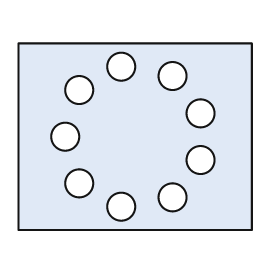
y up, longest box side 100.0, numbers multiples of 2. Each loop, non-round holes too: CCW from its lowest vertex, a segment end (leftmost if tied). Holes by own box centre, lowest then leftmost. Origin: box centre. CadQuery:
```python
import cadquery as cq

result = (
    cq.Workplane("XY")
    .moveTo(-50.0, -40.0)
    .lineTo(50.0, -40.0)
    .lineTo(50.0, 40.0)
    .lineTo(-50.0, 40.0)
    .close()
    .moveTo(-6.0, -30.0)
    .circle(6.0)
    .moveTo(16.0, -26.0)
    .circle(6.0)
    .moveTo(-24.0, -20.0)
    .circle(6.0)
    .moveTo(28.0, -10.0)
    .circle(6.0)
    .moveTo(-30.0, 0.0)
    .circle(6.0)
    .moveTo(28.0, 10.0)
    .circle(6.0)
    .moveTo(-24.0, 20.0)
    .circle(6.0)
    .moveTo(16.0, 26.0)
    .circle(6.0)
    .moveTo(-6.0, 30.0)
    .circle(6.0)
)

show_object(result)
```